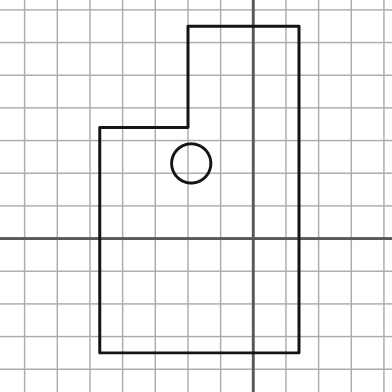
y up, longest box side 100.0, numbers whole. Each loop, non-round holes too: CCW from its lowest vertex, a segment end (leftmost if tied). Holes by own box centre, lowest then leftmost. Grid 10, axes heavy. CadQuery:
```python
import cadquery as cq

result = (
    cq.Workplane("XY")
    .moveTo(-47.0, -35.0)
    .lineTo(14.0, -35.0)
    .lineTo(14.0, 65.0)
    .lineTo(-20.0, 65.0)
    .lineTo(-20.0, 34.0)
    .lineTo(-47.0, 34.0)
    .close()
    .moveTo(-19.0, 23.0)
    .circle(6.0)
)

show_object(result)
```